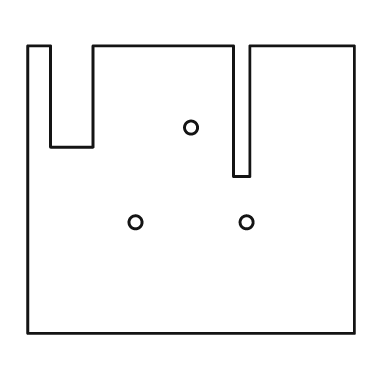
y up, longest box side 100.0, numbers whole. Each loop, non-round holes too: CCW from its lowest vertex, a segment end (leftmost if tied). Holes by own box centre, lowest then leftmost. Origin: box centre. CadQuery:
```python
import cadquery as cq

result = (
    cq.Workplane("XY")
    .moveTo(-50.0, -44.0)
    .lineTo(50.0, -44.0)
    .lineTo(50.0, 44.0)
    .lineTo(18.0, 44.0)
    .lineTo(18.0, 4.0)
    .lineTo(13.0, 4.0)
    .lineTo(13.0, 44.0)
    .lineTo(-30.0, 44.0)
    .lineTo(-30.0, 13.0)
    .lineTo(-43.0, 13.0)
    .lineTo(-43.0, 44.0)
    .lineTo(-50.0, 44.0)
    .close()
    .moveTo(-17.0, -10.0)
    .circle(2.0)
    .moveTo(17.0, -10.0)
    .circle(2.0)
    .moveTo(0.0, 19.0)
    .circle(2.0)
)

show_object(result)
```